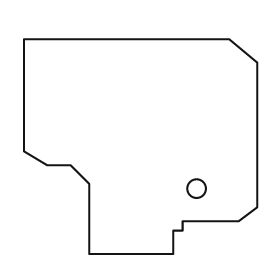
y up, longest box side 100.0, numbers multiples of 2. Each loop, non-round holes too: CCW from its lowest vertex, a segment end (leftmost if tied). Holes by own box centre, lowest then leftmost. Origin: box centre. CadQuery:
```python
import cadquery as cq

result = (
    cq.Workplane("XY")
    .moveTo(-22.0, -46.0)
    .lineTo(14.0, -46.0)
    .lineTo(14.0, -36.0)
    .lineTo(18.0, -36.0)
    .lineTo(18.0, -32.0)
    .lineTo(42.0, -32.0)
    .lineTo(50.0, -26.0)
    .lineTo(50.0, 36.0)
    .lineTo(38.0, 46.0)
    .lineTo(-50.0, 46.0)
    .lineTo(-50.0, -2.0)
    .lineTo(-40.0, -8.0)
    .lineTo(-30.0, -8.0)
    .lineTo(-22.0, -16.0)
    .close()
    .moveTo(24.0, -18.0)
    .circle(4.0)
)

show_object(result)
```